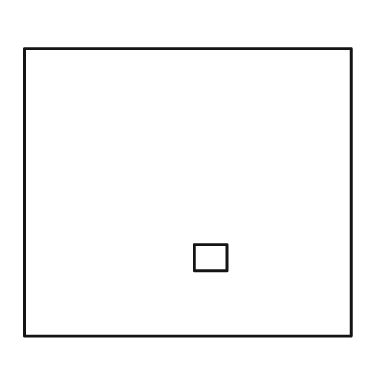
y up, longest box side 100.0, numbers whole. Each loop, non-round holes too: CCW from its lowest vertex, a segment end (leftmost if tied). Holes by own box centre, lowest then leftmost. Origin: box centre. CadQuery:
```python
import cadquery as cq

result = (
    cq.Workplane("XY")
    .moveTo(-50.0, -44.0)
    .lineTo(50.0, -44.0)
    .lineTo(50.0, 44.0)
    .lineTo(-50.0, 44.0)
    .close()
    .moveTo(2.0, -24.0)
    .lineTo(12.0, -24.0)
    .lineTo(12.0, -16.0)
    .lineTo(2.0, -16.0)
    .close()
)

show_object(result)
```